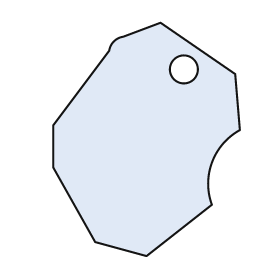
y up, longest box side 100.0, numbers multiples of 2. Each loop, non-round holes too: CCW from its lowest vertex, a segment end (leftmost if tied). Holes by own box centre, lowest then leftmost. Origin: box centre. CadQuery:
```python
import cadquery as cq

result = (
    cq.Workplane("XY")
    .moveTo(0.0, -50.0)
    .lineTo(28.0, -28.0)
    .threePointArc((28.0, -10.0), (40.0, 4.0))
    .lineTo(38.0, 28.0)
    .lineTo(6.0, 50.0)
    .lineTo(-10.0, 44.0)
    .threePointArc((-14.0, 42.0), (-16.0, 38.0))
    .lineTo(-40.0, 6.0)
    .lineTo(-40.0, -12.0)
    .lineTo(-22.0, -44.0)
    .close()
    .moveTo(16.0, 30.0)
    .circle(6.0)
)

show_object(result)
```